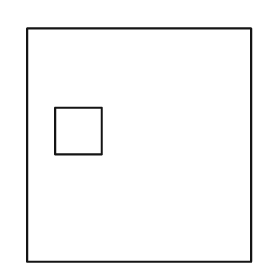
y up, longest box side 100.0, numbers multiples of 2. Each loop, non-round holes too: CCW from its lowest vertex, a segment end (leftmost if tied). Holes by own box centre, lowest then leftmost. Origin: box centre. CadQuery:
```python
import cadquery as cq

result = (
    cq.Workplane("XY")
    .moveTo(-48.0, -50.0)
    .lineTo(48.0, -50.0)
    .lineTo(48.0, 50.0)
    .lineTo(-48.0, 50.0)
    .close()
    .moveTo(-36.0, -4.0)
    .lineTo(-16.0, -4.0)
    .lineTo(-16.0, 16.0)
    .lineTo(-36.0, 16.0)
    .close()
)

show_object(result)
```